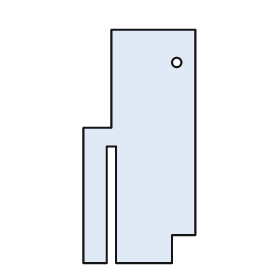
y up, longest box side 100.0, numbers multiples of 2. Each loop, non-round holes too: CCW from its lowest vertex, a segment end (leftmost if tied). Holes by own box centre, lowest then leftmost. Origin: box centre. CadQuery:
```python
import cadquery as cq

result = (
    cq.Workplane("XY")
    .moveTo(-24.0, -50.0)
    .lineTo(-14.0, -50.0)
    .lineTo(-14.0, 0.0)
    .lineTo(-10.0, 0.0)
    .lineTo(-10.0, -50.0)
    .lineTo(14.0, -50.0)
    .lineTo(14.0, -38.0)
    .lineTo(24.0, -38.0)
    .lineTo(24.0, 50.0)
    .lineTo(-12.0, 50.0)
    .lineTo(-12.0, 8.0)
    .lineTo(-24.0, 8.0)
    .close()
    .moveTo(16.0, 36.0)
    .circle(2.0)
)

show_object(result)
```